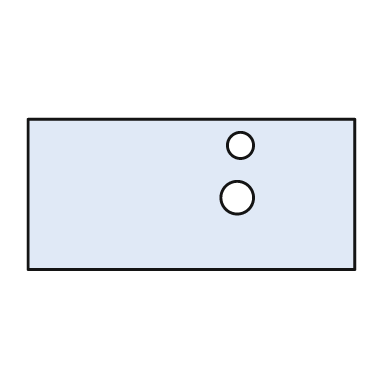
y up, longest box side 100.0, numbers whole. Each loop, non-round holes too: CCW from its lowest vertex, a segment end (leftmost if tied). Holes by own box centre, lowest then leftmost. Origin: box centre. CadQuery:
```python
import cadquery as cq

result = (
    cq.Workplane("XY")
    .moveTo(-50.0, -23.0)
    .lineTo(50.0, -23.0)
    .lineTo(50.0, 23.0)
    .lineTo(-50.0, 23.0)
    .close()
    .moveTo(14.0, -1.0)
    .circle(5.0)
    .moveTo(15.0, 15.0)
    .circle(4.0)
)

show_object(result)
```